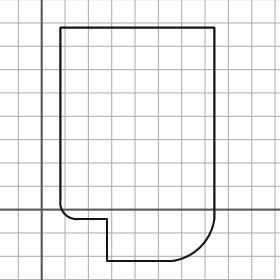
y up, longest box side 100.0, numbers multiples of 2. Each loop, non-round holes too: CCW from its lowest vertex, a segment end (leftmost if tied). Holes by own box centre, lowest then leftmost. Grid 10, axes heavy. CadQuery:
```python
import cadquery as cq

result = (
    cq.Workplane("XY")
    .moveTo(28.0, -22.0)
    .lineTo(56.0, -22.0)
    .threePointArc((68.0, -16.0), (74.0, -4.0))
    .lineTo(74.0, 78.0)
    .lineTo(8.0, 78.0)
    .lineTo(8.0, 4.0)
    .threePointArc((10.0, -2.0), (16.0, -4.0))
    .lineTo(28.0, -4.0)
    .close()
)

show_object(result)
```